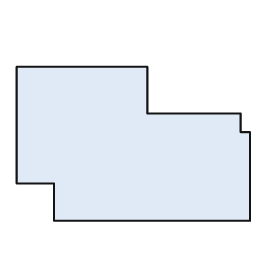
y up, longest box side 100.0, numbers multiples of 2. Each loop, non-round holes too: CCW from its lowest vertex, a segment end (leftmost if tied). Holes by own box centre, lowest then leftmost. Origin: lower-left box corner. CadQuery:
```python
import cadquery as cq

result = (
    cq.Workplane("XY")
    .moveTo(16.0, 0.0)
    .lineTo(100.0, 0.0)
    .lineTo(100.0, 38.0)
    .lineTo(96.0, 38.0)
    .lineTo(96.0, 46.0)
    .lineTo(56.0, 46.0)
    .lineTo(56.0, 66.0)
    .lineTo(0.0, 66.0)
    .lineTo(0.0, 16.0)
    .lineTo(16.0, 16.0)
    .close()
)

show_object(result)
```